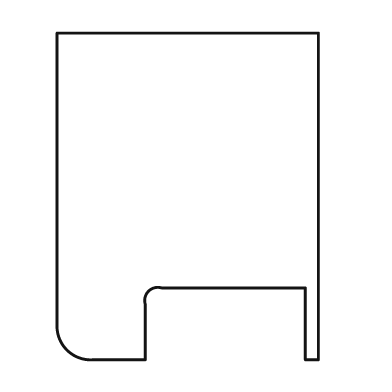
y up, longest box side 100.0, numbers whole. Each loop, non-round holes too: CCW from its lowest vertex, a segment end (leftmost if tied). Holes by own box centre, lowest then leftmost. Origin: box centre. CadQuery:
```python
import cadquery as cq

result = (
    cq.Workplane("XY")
    .moveTo(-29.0, -50.0)
    .lineTo(-13.0, -50.0)
    .lineTo(-13.0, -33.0)
    .threePointArc((-12.0, -29.0), (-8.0, -28.0))
    .lineTo(36.0, -28.0)
    .lineTo(36.0, -50.0)
    .lineTo(40.0, -50.0)
    .lineTo(40.0, 50.0)
    .lineTo(-40.0, 50.0)
    .lineTo(-40.0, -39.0)
    .threePointArc((-37.0, -47.0), (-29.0, -50.0))
    .close()
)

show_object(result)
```